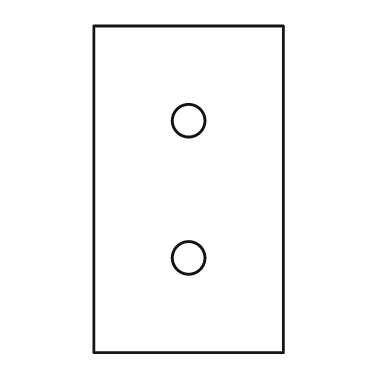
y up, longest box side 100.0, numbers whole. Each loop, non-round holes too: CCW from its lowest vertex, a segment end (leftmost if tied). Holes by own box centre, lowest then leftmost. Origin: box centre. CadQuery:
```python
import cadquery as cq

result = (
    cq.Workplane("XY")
    .moveTo(-29.0, -50.0)
    .lineTo(29.0, -50.0)
    .lineTo(29.0, 50.0)
    .lineTo(-29.0, 50.0)
    .close()
    .moveTo(0.0, -21.0)
    .circle(5.0)
    .moveTo(0.0, 21.0)
    .circle(5.0)
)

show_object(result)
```